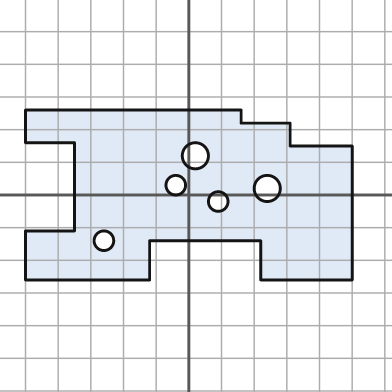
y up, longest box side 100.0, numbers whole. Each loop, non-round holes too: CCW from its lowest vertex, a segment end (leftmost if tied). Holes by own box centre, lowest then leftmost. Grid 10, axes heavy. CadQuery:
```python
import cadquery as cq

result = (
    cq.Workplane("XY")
    .moveTo(-50.0, -26.0)
    .lineTo(-12.0, -26.0)
    .lineTo(-12.0, -14.0)
    .lineTo(22.0, -14.0)
    .lineTo(22.0, -26.0)
    .lineTo(50.0, -26.0)
    .lineTo(50.0, 15.0)
    .lineTo(31.0, 15.0)
    .lineTo(31.0, 22.0)
    .lineTo(16.0, 22.0)
    .lineTo(16.0, 26.0)
    .lineTo(-50.0, 26.0)
    .lineTo(-50.0, 16.0)
    .lineTo(-35.0, 16.0)
    .lineTo(-35.0, -11.0)
    .lineTo(-50.0, -11.0)
    .close()
    .moveTo(-26.0, -14.0)
    .circle(3.0)
    .moveTo(9.0, -2.0)
    .circle(3.0)
    .moveTo(24.0, 2.0)
    .circle(4.0)
    .moveTo(-4.0, 3.0)
    .circle(3.0)
    .moveTo(2.0, 12.0)
    .circle(4.0)
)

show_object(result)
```